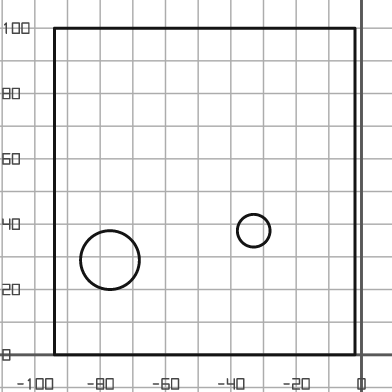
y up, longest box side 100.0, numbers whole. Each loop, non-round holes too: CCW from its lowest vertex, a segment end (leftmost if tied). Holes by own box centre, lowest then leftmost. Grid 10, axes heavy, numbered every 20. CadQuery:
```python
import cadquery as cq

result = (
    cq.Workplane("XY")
    .moveTo(-94.0, 0.0)
    .lineTo(-2.0, 0.0)
    .lineTo(-2.0, 100.0)
    .lineTo(-94.0, 100.0)
    .close()
    .moveTo(-77.0, 29.0)
    .circle(9.0)
    .moveTo(-33.0, 38.0)
    .circle(5.0)
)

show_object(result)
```